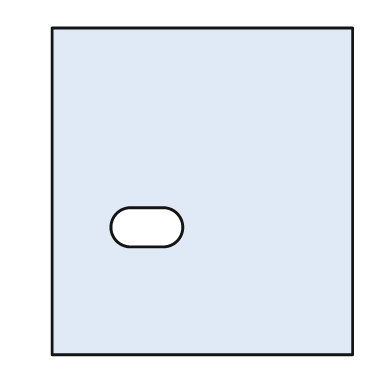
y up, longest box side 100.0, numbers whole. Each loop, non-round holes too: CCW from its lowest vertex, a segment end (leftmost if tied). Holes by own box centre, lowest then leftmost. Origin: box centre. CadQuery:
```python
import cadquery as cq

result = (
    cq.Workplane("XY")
    .moveTo(-46.0, -50.0)
    .lineTo(46.0, -50.0)
    .lineTo(46.0, 50.0)
    .lineTo(-46.0, 50.0)
    .close()
    .moveTo(-22.0, -17.0)
    .lineTo(-12.0, -17.0)
    .threePointArc((-6.0, -11.0), (-12.0, -5.0))
    .lineTo(-22.0, -5.0)
    .threePointArc((-28.0, -11.0), (-22.0, -17.0))
    .close()
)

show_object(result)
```